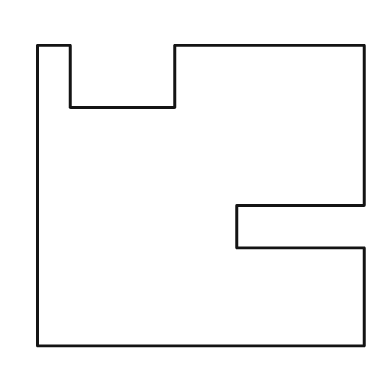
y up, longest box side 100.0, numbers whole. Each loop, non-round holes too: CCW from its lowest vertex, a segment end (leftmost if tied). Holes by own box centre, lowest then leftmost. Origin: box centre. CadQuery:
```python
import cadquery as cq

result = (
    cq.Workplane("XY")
    .moveTo(-50.0, -46.0)
    .lineTo(50.0, -46.0)
    .lineTo(50.0, -16.0)
    .lineTo(11.0, -16.0)
    .lineTo(11.0, -3.0)
    .lineTo(50.0, -3.0)
    .lineTo(50.0, 46.0)
    .lineTo(-8.0, 46.0)
    .lineTo(-8.0, 27.0)
    .lineTo(-40.0, 27.0)
    .lineTo(-40.0, 46.0)
    .lineTo(-50.0, 46.0)
    .close()
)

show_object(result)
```